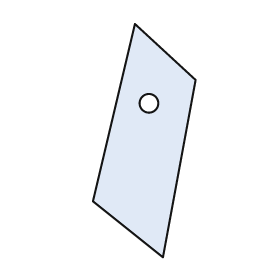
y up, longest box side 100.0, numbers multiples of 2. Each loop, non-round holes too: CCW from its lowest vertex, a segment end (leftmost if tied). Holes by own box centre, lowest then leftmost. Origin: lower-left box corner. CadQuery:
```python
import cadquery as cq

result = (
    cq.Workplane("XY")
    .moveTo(30.0, 0.0)
    .lineTo(44.0, 76.0)
    .lineTo(18.0, 100.0)
    .lineTo(0.0, 24.0)
    .close()
    .moveTo(24.0, 66.0)
    .circle(4.0)
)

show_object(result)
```